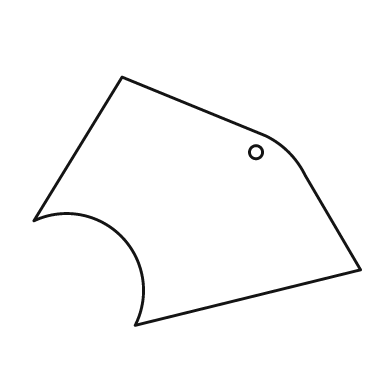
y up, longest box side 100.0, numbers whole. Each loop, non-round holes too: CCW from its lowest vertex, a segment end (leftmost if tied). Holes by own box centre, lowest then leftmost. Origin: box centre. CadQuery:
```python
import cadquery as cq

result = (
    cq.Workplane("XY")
    .moveTo(-19.0, -38.0)
    .lineTo(50.0, -21.0)
    .lineTo(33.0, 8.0)
    .threePointArc((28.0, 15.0), (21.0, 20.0))
    .lineTo(-23.0, 38.0)
    .lineTo(-50.0, -6.0)
    .threePointArc((-23.0, -11.0), (-19.0, -38.0))
    .close()
    .moveTo(18.0, 15.0)
    .circle(2.0)
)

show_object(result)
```